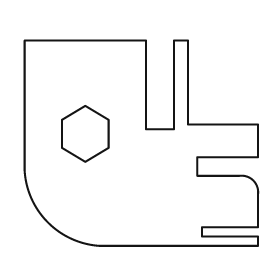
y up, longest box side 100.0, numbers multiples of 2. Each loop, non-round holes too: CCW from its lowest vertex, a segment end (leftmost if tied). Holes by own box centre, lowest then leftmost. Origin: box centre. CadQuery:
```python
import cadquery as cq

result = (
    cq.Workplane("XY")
    .moveTo(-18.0, -44.0)
    .lineTo(50.0, -44.0)
    .lineTo(50.0, -40.0)
    .lineTo(26.0, -40.0)
    .lineTo(26.0, -36.0)
    .lineTo(50.0, -36.0)
    .lineTo(50.0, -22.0)
    .threePointArc((48.0, -16.0), (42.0, -14.0))
    .lineTo(24.0, -14.0)
    .lineTo(24.0, -6.0)
    .lineTo(50.0, -6.0)
    .lineTo(50.0, 8.0)
    .lineTo(20.0, 8.0)
    .lineTo(20.0, 44.0)
    .lineTo(14.0, 44.0)
    .lineTo(14.0, 6.0)
    .lineTo(2.0, 6.0)
    .lineTo(2.0, 44.0)
    .lineTo(-50.0, 44.0)
    .lineTo(-50.0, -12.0)
    .threePointArc((-40.0, -34.0), (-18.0, -44.0))
    .close()
    .moveTo(-24.0, -8.0)
    .lineTo(-14.0, -2.0)
    .lineTo(-14.0, 10.0)
    .lineTo(-24.0, 16.0)
    .lineTo(-34.0, 10.0)
    .lineTo(-34.0, -2.0)
    .close()
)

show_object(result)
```